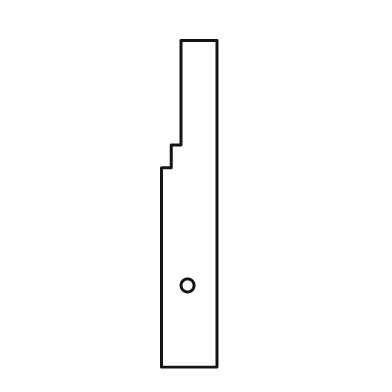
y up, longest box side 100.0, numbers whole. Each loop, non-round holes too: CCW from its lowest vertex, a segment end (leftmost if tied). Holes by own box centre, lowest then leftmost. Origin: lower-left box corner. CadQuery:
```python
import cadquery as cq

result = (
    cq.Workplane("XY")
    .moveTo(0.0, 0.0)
    .lineTo(17.0, 0.0)
    .lineTo(17.0, 100.0)
    .lineTo(6.0, 100.0)
    .lineTo(6.0, 68.0)
    .lineTo(3.0, 68.0)
    .lineTo(3.0, 61.0)
    .lineTo(0.0, 61.0)
    .close()
    .moveTo(8.0, 25.0)
    .circle(2.0)
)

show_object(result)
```